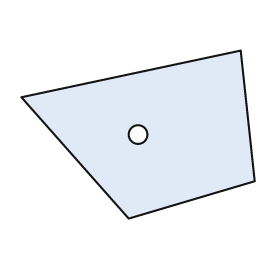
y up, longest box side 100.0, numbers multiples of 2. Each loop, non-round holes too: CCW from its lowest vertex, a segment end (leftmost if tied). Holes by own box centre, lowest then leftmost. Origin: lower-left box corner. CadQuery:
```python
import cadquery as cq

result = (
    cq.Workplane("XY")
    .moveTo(46.0, 0.0)
    .lineTo(100.0, 16.0)
    .lineTo(94.0, 72.0)
    .lineTo(0.0, 52.0)
    .close()
    .moveTo(50.0, 36.0)
    .circle(4.0)
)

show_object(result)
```